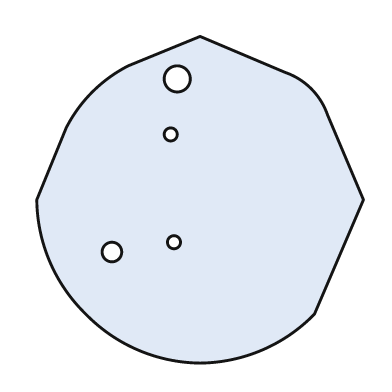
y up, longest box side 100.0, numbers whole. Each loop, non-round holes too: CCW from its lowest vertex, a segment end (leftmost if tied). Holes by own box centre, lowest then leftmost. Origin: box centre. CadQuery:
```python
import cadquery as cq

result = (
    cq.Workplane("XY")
    .moveTo(0.0, -50.0)
    .threePointArc((19.0, -46.0), (35.0, -35.0))
    .lineTo(50.0, 0.0)
    .lineTo(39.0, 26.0)
    .threePointArc((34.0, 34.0), (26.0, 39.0))
    .lineTo(0.0, 50.0)
    .lineTo(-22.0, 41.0)
    .threePointArc((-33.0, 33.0), (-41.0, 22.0))
    .lineTo(-50.0, 0.0)
    .threePointArc((-46.0, -19.0), (-35.0, -35.0))
    .threePointArc((-19.0, -46.0), (0.0, -50.0))
    .close()
    .moveTo(-27.0, -16.0)
    .circle(3.0)
    .moveTo(-8.0, -13.0)
    .circle(2.0)
    .moveTo(-9.0, 20.0)
    .circle(2.0)
    .moveTo(-7.0, 37.0)
    .circle(4.0)
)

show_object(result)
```